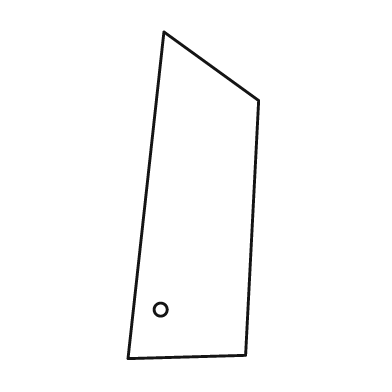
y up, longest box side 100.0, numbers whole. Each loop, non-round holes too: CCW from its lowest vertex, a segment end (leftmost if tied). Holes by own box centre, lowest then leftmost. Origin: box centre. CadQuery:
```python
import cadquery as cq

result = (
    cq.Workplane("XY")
    .moveTo(-20.0, -50.0)
    .lineTo(16.0, -49.0)
    .lineTo(20.0, 29.0)
    .lineTo(-9.0, 50.0)
    .close()
    .moveTo(-10.0, -35.0)
    .circle(2.0)
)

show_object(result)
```